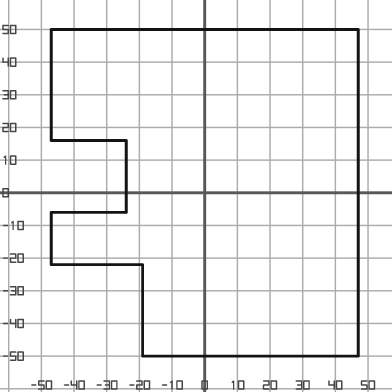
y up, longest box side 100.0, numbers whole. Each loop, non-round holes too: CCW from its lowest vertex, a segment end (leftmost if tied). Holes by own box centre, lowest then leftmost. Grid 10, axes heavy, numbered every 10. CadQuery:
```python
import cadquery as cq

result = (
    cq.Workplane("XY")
    .moveTo(-19.0, -50.0)
    .lineTo(47.0, -50.0)
    .lineTo(47.0, 50.0)
    .lineTo(-47.0, 50.0)
    .lineTo(-47.0, 16.0)
    .lineTo(-24.0, 16.0)
    .lineTo(-24.0, -6.0)
    .lineTo(-47.0, -6.0)
    .lineTo(-47.0, -22.0)
    .lineTo(-19.0, -22.0)
    .close()
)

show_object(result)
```